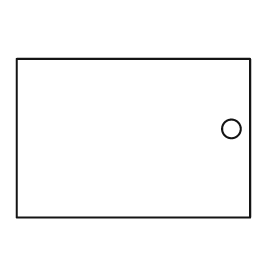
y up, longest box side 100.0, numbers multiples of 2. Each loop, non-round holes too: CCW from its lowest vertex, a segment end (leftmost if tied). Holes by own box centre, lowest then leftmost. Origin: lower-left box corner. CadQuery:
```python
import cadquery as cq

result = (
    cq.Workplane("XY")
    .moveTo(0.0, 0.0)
    .lineTo(100.0, 0.0)
    .lineTo(100.0, 68.0)
    .lineTo(0.0, 68.0)
    .close()
    .moveTo(92.0, 38.0)
    .circle(4.0)
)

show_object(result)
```